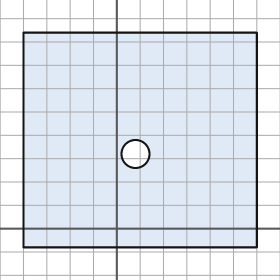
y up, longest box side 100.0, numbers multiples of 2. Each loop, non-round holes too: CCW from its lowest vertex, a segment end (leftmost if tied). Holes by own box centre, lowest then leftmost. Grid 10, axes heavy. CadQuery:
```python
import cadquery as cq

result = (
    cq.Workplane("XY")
    .moveTo(-40.0, -8.0)
    .lineTo(60.0, -8.0)
    .lineTo(60.0, 84.0)
    .lineTo(-40.0, 84.0)
    .close()
    .moveTo(8.0, 32.0)
    .circle(6.0)
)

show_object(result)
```